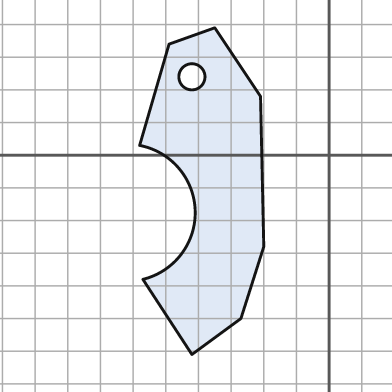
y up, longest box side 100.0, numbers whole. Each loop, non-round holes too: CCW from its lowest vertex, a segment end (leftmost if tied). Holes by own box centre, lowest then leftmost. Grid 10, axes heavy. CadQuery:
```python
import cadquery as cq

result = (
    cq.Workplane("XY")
    .moveTo(-42.0, -61.0)
    .lineTo(-27.0, -50.0)
    .lineTo(-20.0, -28.0)
    .lineTo(-21.0, 18.0)
    .lineTo(-35.0, 39.0)
    .lineTo(-49.0, 34.0)
    .lineTo(-58.0, 3.0)
    .threePointArc((-41.0, -17.0), (-57.0, -38.0))
    .close()
    .moveTo(-42.0, 24.0)
    .circle(4.0)
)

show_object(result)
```